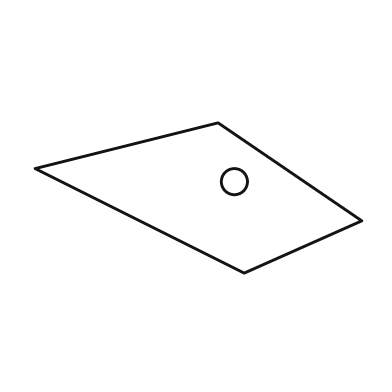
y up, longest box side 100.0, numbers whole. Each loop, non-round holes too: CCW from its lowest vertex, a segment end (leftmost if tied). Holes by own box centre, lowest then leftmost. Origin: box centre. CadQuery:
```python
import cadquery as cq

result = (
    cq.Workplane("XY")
    .moveTo(14.0, -23.0)
    .lineTo(50.0, -7.0)
    .lineTo(6.0, 23.0)
    .lineTo(-50.0, 9.0)
    .close()
    .moveTo(11.0, 5.0)
    .circle(4.0)
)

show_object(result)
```